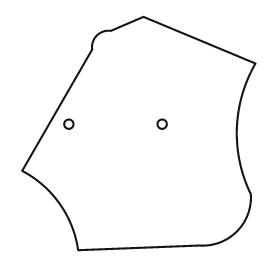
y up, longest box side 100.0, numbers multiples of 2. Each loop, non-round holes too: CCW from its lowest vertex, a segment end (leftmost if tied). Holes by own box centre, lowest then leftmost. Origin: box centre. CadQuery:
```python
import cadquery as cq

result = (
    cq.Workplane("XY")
    .moveTo(-26.0, -50.0)
    .lineTo(26.0, -48.0)
    .threePointArc((42.0, -42.0), (48.0, -26.0))
    .threePointArc((42.0, 2.0), (50.0, 30.0))
    .lineTo(2.0, 50.0)
    .lineTo(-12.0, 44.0)
    .threePointArc((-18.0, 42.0), (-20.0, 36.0))
    .lineTo(-50.0, -16.0)
    .threePointArc((-34.0, -30.0), (-26.0, -50.0))
    .close()
    .moveTo(-30.0, 4.0)
    .circle(2.0)
    .moveTo(10.0, 4.0)
    .circle(2.0)
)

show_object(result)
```